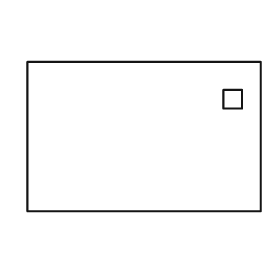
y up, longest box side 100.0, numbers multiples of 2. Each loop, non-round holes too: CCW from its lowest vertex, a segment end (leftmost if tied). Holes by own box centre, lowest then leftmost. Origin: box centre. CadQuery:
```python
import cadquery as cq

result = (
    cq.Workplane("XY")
    .moveTo(-50.0, -32.0)
    .lineTo(50.0, -32.0)
    .lineTo(50.0, 32.0)
    .lineTo(-50.0, 32.0)
    .close()
    .moveTo(34.0, 12.0)
    .lineTo(42.0, 12.0)
    .lineTo(42.0, 20.0)
    .lineTo(34.0, 20.0)
    .close()
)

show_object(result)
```